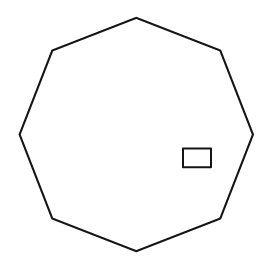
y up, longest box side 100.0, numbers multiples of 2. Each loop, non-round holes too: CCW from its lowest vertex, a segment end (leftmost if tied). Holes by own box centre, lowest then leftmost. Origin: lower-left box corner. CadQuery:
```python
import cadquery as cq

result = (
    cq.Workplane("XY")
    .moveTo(50.0, 0.0)
    .lineTo(86.0, 14.0)
    .lineTo(100.0, 50.0)
    .lineTo(86.0, 86.0)
    .lineTo(50.0, 100.0)
    .lineTo(14.0, 86.0)
    .lineTo(0.0, 50.0)
    .lineTo(14.0, 14.0)
    .close()
    .moveTo(70.0, 36.0)
    .lineTo(82.0, 36.0)
    .lineTo(82.0, 44.0)
    .lineTo(70.0, 44.0)
    .close()
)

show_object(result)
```